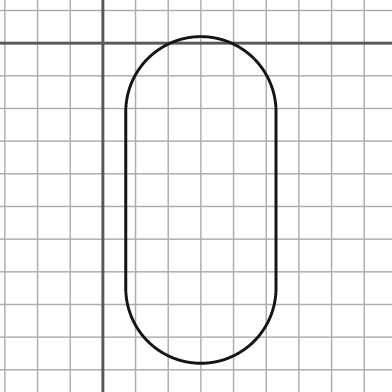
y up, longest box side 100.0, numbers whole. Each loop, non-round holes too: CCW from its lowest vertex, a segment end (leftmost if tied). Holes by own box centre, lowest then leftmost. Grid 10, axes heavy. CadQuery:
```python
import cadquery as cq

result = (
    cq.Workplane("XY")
    .moveTo(7.0, -75.0)
    .threePointArc((30.0, -98.0), (53.0, -75.0))
    .lineTo(53.0, -21.0)
    .threePointArc((30.0, 2.0), (7.0, -21.0))
    .close()
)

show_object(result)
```